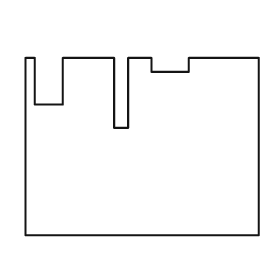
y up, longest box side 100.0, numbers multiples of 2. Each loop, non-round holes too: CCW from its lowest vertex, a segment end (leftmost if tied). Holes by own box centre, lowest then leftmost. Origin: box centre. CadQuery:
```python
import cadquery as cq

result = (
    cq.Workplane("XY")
    .moveTo(-50.0, -38.0)
    .lineTo(50.0, -38.0)
    .lineTo(50.0, 38.0)
    .lineTo(20.0, 38.0)
    .lineTo(20.0, 32.0)
    .lineTo(4.0, 32.0)
    .lineTo(4.0, 38.0)
    .lineTo(-6.0, 38.0)
    .lineTo(-6.0, 8.0)
    .lineTo(-12.0, 8.0)
    .lineTo(-12.0, 38.0)
    .lineTo(-34.0, 38.0)
    .lineTo(-34.0, 18.0)
    .lineTo(-46.0, 18.0)
    .lineTo(-46.0, 38.0)
    .lineTo(-50.0, 38.0)
    .close()
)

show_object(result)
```